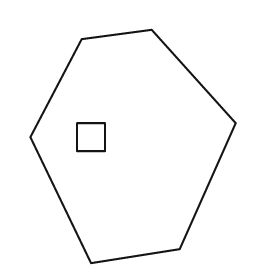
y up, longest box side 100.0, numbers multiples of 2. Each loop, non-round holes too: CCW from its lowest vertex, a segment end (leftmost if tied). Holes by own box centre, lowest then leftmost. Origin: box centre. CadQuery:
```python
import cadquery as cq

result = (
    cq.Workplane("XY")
    .moveTo(-18.0, -50.0)
    .lineTo(20.0, -44.0)
    .lineTo(44.0, 10.0)
    .lineTo(8.0, 50.0)
    .lineTo(-22.0, 46.0)
    .lineTo(-44.0, 4.0)
    .close()
    .moveTo(-24.0, -2.0)
    .lineTo(-12.0, -2.0)
    .lineTo(-12.0, 10.0)
    .lineTo(-24.0, 10.0)
    .close()
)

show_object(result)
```